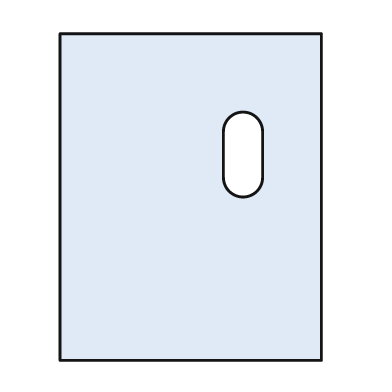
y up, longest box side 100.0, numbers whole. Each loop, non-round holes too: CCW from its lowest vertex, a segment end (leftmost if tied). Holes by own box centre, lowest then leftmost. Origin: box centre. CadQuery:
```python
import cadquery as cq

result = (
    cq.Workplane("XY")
    .moveTo(-40.0, -50.0)
    .lineTo(40.0, -50.0)
    .lineTo(40.0, 50.0)
    .lineTo(-40.0, 50.0)
    .close()
    .moveTo(10.0, 6.0)
    .threePointArc((16.0, 0.0), (22.0, 6.0))
    .lineTo(22.0, 20.0)
    .threePointArc((16.0, 26.0), (10.0, 20.0))
    .close()
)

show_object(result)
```